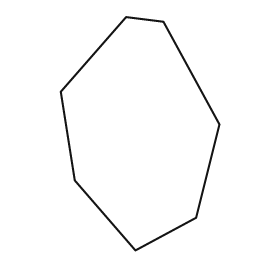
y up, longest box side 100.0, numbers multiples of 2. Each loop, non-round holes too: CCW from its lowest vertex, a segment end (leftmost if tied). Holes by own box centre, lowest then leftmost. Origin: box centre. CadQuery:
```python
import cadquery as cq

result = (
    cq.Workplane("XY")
    .moveTo(-2.0, -50.0)
    .lineTo(24.0, -36.0)
    .lineTo(34.0, 4.0)
    .lineTo(10.0, 48.0)
    .lineTo(-6.0, 50.0)
    .lineTo(-34.0, 18.0)
    .lineTo(-28.0, -20.0)
    .close()
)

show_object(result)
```